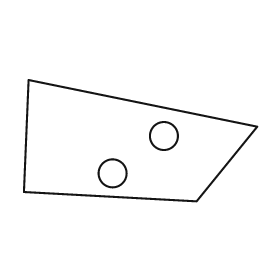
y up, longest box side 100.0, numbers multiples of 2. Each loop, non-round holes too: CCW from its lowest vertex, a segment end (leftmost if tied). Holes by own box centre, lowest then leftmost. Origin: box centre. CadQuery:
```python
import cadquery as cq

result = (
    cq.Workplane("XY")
    .moveTo(24.0, -26.0)
    .lineTo(50.0, 6.0)
    .lineTo(-48.0, 26.0)
    .lineTo(-50.0, -22.0)
    .close()
    .moveTo(-12.0, -14.0)
    .circle(6.0)
    .moveTo(10.0, 2.0)
    .circle(6.0)
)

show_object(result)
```